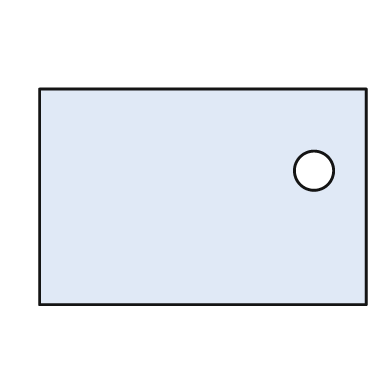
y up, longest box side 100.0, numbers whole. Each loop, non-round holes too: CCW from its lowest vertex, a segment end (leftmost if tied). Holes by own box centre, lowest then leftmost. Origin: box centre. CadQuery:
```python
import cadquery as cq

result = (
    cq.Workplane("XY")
    .moveTo(-50.0, -33.0)
    .lineTo(50.0, -33.0)
    .lineTo(50.0, 33.0)
    .lineTo(-50.0, 33.0)
    .close()
    .moveTo(34.0, 8.0)
    .circle(6.0)
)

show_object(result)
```